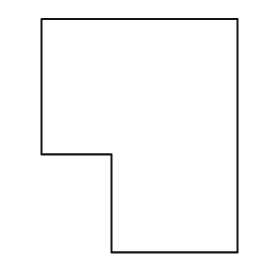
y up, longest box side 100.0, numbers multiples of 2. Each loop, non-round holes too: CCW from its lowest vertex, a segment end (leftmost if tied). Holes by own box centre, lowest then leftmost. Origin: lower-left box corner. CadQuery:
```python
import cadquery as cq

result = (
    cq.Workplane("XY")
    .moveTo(30.0, 0.0)
    .lineTo(84.0, 0.0)
    .lineTo(84.0, 100.0)
    .lineTo(0.0, 100.0)
    .lineTo(0.0, 42.0)
    .lineTo(30.0, 42.0)
    .close()
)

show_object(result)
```